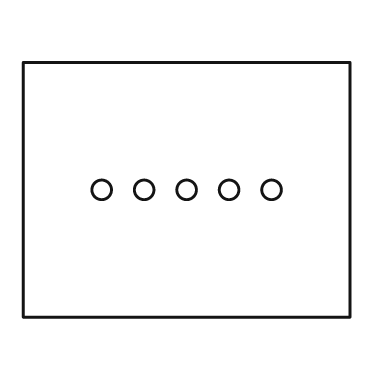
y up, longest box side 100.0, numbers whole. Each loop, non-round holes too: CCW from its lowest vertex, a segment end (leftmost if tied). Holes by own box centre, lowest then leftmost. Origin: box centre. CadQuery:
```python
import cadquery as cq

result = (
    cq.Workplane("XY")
    .moveTo(-50.0, -39.0)
    .lineTo(50.0, -39.0)
    .lineTo(50.0, 39.0)
    .lineTo(-50.0, 39.0)
    .close()
    .moveTo(-26.0, 0.0)
    .circle(3.0)
    .moveTo(-13.0, 0.0)
    .circle(3.0)
    .moveTo(0.0, 0.0)
    .circle(3.0)
    .moveTo(13.0, 0.0)
    .circle(3.0)
    .moveTo(26.0, 0.0)
    .circle(3.0)
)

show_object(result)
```